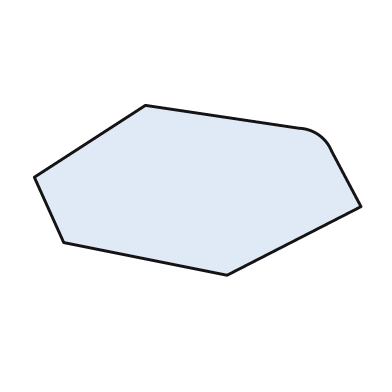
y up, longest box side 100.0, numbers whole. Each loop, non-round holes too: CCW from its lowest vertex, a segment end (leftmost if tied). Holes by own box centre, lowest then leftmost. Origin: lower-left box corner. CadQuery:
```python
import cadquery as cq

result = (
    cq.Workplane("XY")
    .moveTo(59.0, 0.0)
    .lineTo(100.0, 21.0)
    .lineTo(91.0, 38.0)
    .threePointArc((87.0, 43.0), (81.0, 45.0))
    .lineTo(34.0, 52.0)
    .lineTo(0.0, 30.0)
    .lineTo(9.0, 10.0)
    .close()
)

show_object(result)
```